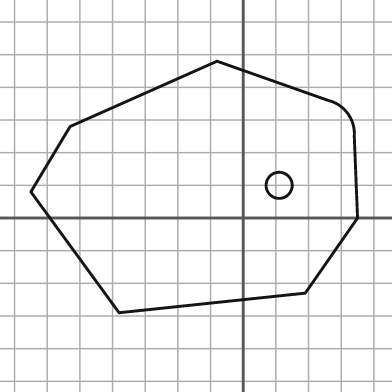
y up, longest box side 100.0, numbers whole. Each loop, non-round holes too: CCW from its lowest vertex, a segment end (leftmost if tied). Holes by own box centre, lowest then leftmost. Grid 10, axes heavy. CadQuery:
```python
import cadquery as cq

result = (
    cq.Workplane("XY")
    .moveTo(-38.0, -29.0)
    .lineTo(19.0, -23.0)
    .lineTo(35.0, 0.0)
    .lineTo(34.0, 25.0)
    .threePointArc((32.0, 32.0), (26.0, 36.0))
    .lineTo(-8.0, 48.0)
    .lineTo(-53.0, 28.0)
    .lineTo(-65.0, 8.0)
    .close()
    .moveTo(11.0, 10.0)
    .circle(4.0)
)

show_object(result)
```